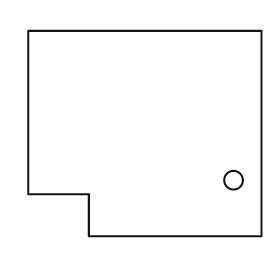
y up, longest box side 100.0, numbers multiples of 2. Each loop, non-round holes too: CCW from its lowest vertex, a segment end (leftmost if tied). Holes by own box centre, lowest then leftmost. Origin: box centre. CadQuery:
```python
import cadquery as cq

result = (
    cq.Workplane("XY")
    .moveTo(-24.0, -44.0)
    .lineTo(50.0, -44.0)
    .lineTo(50.0, 44.0)
    .lineTo(-50.0, 44.0)
    .lineTo(-50.0, -26.0)
    .lineTo(-24.0, -26.0)
    .close()
    .moveTo(38.0, -20.0)
    .circle(4.0)
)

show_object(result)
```